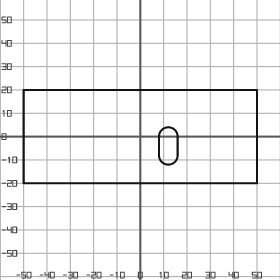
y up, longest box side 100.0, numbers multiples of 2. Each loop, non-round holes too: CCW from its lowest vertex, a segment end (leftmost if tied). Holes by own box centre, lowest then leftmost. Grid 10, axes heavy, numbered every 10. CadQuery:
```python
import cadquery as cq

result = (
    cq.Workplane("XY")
    .moveTo(-50.0, -20.0)
    .lineTo(50.0, -20.0)
    .lineTo(50.0, 20.0)
    .lineTo(-50.0, 20.0)
    .close()
    .moveTo(8.0, -8.0)
    .threePointArc((12.0, -12.0), (16.0, -8.0))
    .lineTo(16.0, 0.0)
    .threePointArc((12.0, 4.0), (8.0, 0.0))
    .close()
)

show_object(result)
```